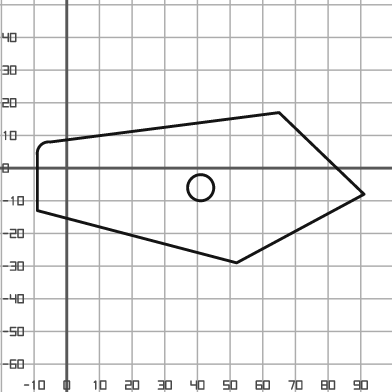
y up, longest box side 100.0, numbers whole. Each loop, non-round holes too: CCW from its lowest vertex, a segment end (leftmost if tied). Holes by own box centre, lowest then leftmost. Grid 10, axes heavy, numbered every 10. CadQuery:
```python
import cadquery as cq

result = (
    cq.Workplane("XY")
    .moveTo(52.0, -29.0)
    .lineTo(91.0, -8.0)
    .lineTo(65.0, 17.0)
    .lineTo(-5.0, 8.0)
    .threePointArc((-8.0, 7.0), (-9.0, 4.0))
    .lineTo(-9.0, -13.0)
    .close()
    .moveTo(41.0, -6.0)
    .circle(4.0)
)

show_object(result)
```